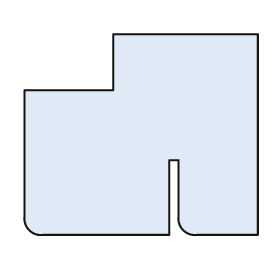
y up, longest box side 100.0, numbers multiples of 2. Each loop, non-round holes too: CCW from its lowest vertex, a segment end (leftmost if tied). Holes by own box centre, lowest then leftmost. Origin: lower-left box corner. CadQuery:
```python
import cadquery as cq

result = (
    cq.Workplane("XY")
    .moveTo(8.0, 0.0)
    .lineTo(62.0, 0.0)
    .lineTo(62.0, 32.0)
    .lineTo(66.0, 32.0)
    .lineTo(66.0, 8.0)
    .threePointArc((68.0, 2.0), (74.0, 0.0))
    .lineTo(100.0, 0.0)
    .lineTo(100.0, 86.0)
    .lineTo(38.0, 86.0)
    .lineTo(38.0, 62.0)
    .lineTo(0.0, 62.0)
    .lineTo(0.0, 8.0)
    .threePointArc((2.0, 2.0), (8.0, 0.0))
    .close()
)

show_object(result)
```